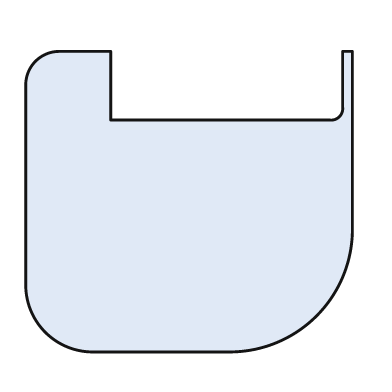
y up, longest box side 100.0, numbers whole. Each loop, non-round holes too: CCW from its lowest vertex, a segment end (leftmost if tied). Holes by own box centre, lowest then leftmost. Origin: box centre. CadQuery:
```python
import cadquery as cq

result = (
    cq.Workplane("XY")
    .moveTo(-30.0, -46.0)
    .lineTo(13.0, -46.0)
    .threePointArc((39.0, -35.0), (50.0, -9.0))
    .lineTo(50.0, 46.0)
    .lineTo(47.0, 46.0)
    .lineTo(47.0, 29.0)
    .threePointArc((46.0, 26.0), (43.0, 25.0))
    .lineTo(-24.0, 25.0)
    .lineTo(-24.0, 46.0)
    .lineTo(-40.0, 46.0)
    .threePointArc((-47.0, 43.0), (-50.0, 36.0))
    .lineTo(-50.0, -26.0)
    .threePointArc((-44.0, -40.0), (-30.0, -46.0))
    .close()
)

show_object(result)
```